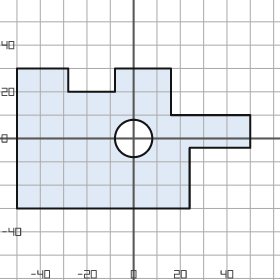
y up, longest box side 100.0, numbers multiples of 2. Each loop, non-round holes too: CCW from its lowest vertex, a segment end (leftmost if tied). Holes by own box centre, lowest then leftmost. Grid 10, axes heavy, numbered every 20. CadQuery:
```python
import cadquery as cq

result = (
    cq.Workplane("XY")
    .moveTo(-50.0, -30.0)
    .lineTo(24.0, -30.0)
    .lineTo(24.0, -4.0)
    .lineTo(50.0, -4.0)
    .lineTo(50.0, 10.0)
    .lineTo(16.0, 10.0)
    .lineTo(16.0, 30.0)
    .lineTo(-8.0, 30.0)
    .lineTo(-8.0, 20.0)
    .lineTo(-28.0, 20.0)
    .lineTo(-28.0, 30.0)
    .lineTo(-50.0, 30.0)
    .close()
    .moveTo(0.0, 0.0)
    .circle(8.0)
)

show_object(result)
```